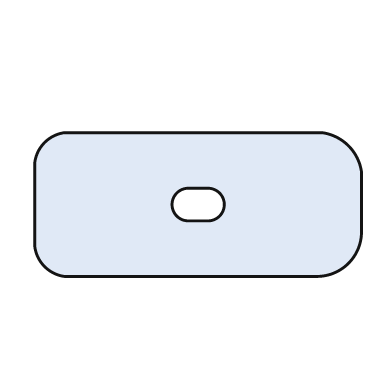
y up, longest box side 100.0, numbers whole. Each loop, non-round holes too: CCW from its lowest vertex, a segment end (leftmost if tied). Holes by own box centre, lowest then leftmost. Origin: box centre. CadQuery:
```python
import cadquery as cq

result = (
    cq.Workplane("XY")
    .moveTo(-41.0, -22.0)
    .lineTo(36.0, -22.0)
    .threePointArc((46.0, -18.0), (50.0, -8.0))
    .lineTo(50.0, 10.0)
    .threePointArc((46.0, 18.0), (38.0, 22.0))
    .lineTo(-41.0, 22.0)
    .threePointArc((-47.0, 19.0), (-50.0, 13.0))
    .lineTo(-50.0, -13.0)
    .threePointArc((-47.0, -19.0), (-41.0, -22.0))
    .close()
    .moveTo(-3.0, -5.0)
    .lineTo(3.0, -5.0)
    .threePointArc((8.0, 0.0), (3.0, 5.0))
    .lineTo(-3.0, 5.0)
    .threePointArc((-8.0, 0.0), (-3.0, -5.0))
    .close()
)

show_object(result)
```